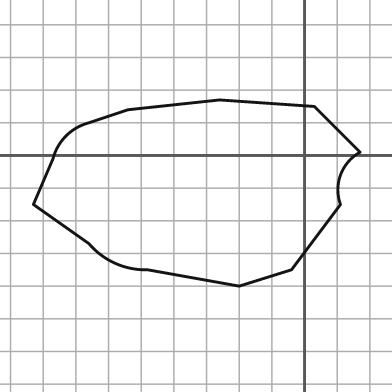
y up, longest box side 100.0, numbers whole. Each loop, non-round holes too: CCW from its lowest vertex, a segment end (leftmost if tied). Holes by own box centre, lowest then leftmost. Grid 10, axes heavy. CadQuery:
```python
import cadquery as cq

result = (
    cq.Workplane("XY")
    .moveTo(-20.0, -40.0)
    .lineTo(-4.0, -35.0)
    .lineTo(11.0, -15.0)
    .threePointArc((11.0, -6.0), (17.0, 1.0))
    .lineTo(3.0, 15.0)
    .lineTo(-26.0, 17.0)
    .lineTo(-54.0, 14.0)
    .lineTo(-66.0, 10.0)
    .threePointArc((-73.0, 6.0), (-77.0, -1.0))
    .lineTo(-83.0, -15.0)
    .lineTo(-66.0, -27.0)
    .threePointArc((-58.0, -33.0), (-48.0, -35.0))
    .close()
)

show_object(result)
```